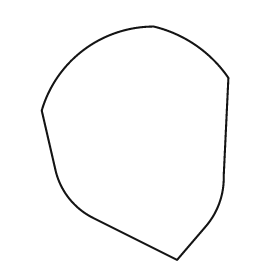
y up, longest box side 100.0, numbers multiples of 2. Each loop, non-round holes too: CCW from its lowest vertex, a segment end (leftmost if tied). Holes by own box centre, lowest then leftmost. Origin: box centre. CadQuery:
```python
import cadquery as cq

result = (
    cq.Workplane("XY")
    .moveTo(18.0, -50.0)
    .lineTo(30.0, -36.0)
    .threePointArc((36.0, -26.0), (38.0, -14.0))
    .lineTo(40.0, 28.0)
    .threePointArc((26.0, 42.0), (8.0, 50.0))
    .threePointArc((-22.0, 40.0), (-40.0, 14.0))
    .lineTo(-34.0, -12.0)
    .threePointArc((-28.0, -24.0), (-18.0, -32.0))
    .close()
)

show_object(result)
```